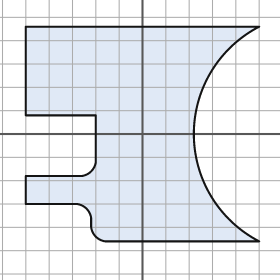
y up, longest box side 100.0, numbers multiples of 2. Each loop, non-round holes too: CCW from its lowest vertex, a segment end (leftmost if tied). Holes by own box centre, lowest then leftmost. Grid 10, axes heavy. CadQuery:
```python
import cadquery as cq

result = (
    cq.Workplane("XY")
    .moveTo(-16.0, -46.0)
    .lineTo(50.0, -46.0)
    .threePointArc((22.0, 0.0), (50.0, 46.0))
    .lineTo(-50.0, 46.0)
    .lineTo(-50.0, 8.0)
    .lineTo(-20.0, 8.0)
    .lineTo(-20.0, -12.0)
    .threePointArc((-22.0, -16.0), (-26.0, -18.0))
    .lineTo(-50.0, -18.0)
    .lineTo(-50.0, -30.0)
    .lineTo(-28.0, -30.0)
    .threePointArc((-24.0, -32.0), (-22.0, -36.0))
    .lineTo(-22.0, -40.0)
    .threePointArc((-20.0, -44.0), (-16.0, -46.0))
    .close()
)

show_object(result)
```